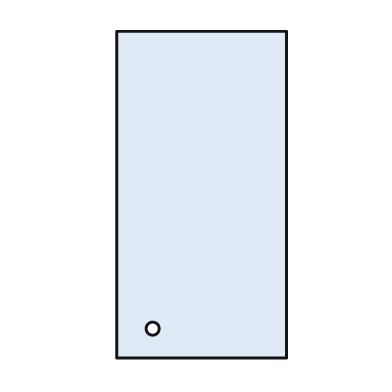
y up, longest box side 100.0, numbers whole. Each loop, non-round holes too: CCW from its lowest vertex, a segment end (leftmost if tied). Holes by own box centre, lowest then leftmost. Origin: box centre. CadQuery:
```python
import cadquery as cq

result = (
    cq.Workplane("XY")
    .moveTo(-26.0, -50.0)
    .lineTo(26.0, -50.0)
    .lineTo(26.0, 50.0)
    .lineTo(-26.0, 50.0)
    .close()
    .moveTo(-15.0, -41.0)
    .circle(2.0)
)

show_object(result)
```